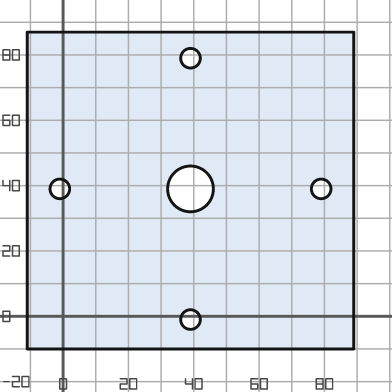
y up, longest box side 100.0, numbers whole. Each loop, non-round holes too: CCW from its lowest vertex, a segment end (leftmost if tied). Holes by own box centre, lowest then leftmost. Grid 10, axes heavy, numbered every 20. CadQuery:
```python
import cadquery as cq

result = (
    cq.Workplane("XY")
    .moveTo(-11.0, -10.0)
    .lineTo(89.0, -10.0)
    .lineTo(89.0, 87.0)
    .lineTo(-11.0, 87.0)
    .close()
    .moveTo(39.0, -1.0)
    .circle(3.0)
    .moveTo(-1.0, 39.0)
    .circle(3.0)
    .moveTo(39.0, 39.0)
    .circle(7.0)
    .moveTo(79.0, 39.0)
    .circle(3.0)
    .moveTo(39.0, 79.0)
    .circle(3.0)
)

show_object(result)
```